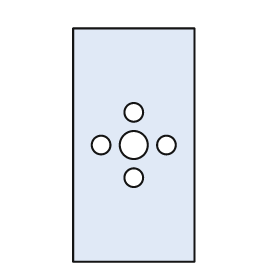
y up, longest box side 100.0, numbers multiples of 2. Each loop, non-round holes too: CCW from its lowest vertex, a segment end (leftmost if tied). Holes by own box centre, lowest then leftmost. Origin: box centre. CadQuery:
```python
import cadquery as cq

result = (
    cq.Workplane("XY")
    .moveTo(-26.0, -50.0)
    .lineTo(26.0, -50.0)
    .lineTo(26.0, 50.0)
    .lineTo(-26.0, 50.0)
    .close()
    .moveTo(0.0, -14.0)
    .circle(4.0)
    .moveTo(-14.0, 0.0)
    .circle(4.0)
    .moveTo(0.0, 0.0)
    .circle(6.0)
    .moveTo(14.0, 0.0)
    .circle(4.0)
    .moveTo(0.0, 14.0)
    .circle(4.0)
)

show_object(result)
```